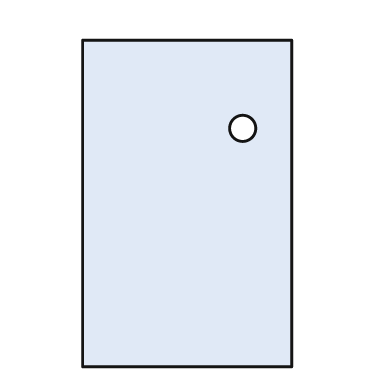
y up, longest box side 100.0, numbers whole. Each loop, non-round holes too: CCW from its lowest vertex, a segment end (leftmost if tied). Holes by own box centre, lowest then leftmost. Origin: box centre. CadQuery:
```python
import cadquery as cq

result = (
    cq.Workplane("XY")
    .moveTo(-32.0, -50.0)
    .lineTo(32.0, -50.0)
    .lineTo(32.0, 50.0)
    .lineTo(-32.0, 50.0)
    .close()
    .moveTo(17.0, 23.0)
    .circle(4.0)
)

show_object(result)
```